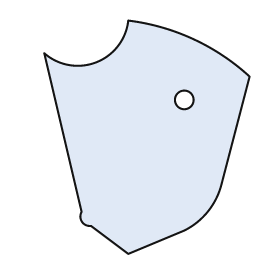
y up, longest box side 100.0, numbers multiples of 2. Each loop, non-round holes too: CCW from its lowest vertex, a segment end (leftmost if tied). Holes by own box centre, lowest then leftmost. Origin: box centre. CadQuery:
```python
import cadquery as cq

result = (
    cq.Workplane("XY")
    .moveTo(-8.0, -50.0)
    .lineTo(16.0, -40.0)
    .threePointArc((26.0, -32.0), (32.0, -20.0))
    .lineTo(44.0, 26.0)
    .threePointArc((20.0, 42.0), (-8.0, 50.0))
    .threePointArc((-22.0, 32.0), (-44.0, 36.0))
    .lineTo(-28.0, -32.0)
    .threePointArc((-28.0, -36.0), (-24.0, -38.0))
    .close()
    .moveTo(16.0, 16.0)
    .circle(4.0)
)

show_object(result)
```